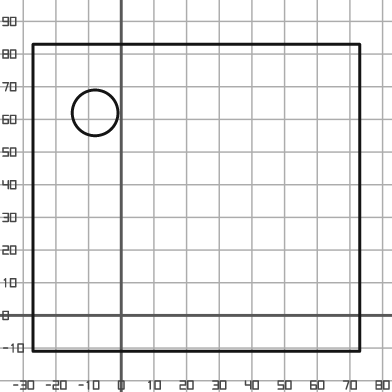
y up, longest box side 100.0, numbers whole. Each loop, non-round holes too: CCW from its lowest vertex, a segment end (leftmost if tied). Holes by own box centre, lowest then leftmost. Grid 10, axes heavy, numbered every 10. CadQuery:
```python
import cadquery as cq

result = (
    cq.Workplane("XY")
    .moveTo(-27.0, -11.0)
    .lineTo(73.0, -11.0)
    .lineTo(73.0, 83.0)
    .lineTo(-27.0, 83.0)
    .close()
    .moveTo(-8.0, 62.0)
    .circle(7.0)
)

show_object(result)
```